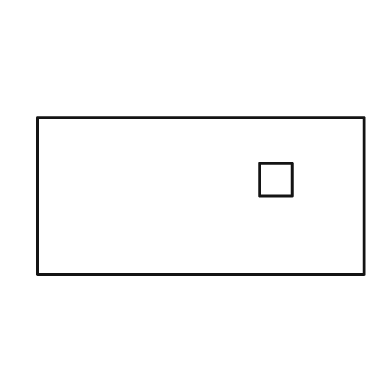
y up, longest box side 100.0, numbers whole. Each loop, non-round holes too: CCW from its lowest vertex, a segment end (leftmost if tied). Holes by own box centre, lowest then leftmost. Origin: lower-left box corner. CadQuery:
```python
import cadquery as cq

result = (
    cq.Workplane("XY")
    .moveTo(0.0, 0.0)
    .lineTo(100.0, 0.0)
    .lineTo(100.0, 48.0)
    .lineTo(0.0, 48.0)
    .close()
    .moveTo(68.0, 24.0)
    .lineTo(78.0, 24.0)
    .lineTo(78.0, 34.0)
    .lineTo(68.0, 34.0)
    .close()
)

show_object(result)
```